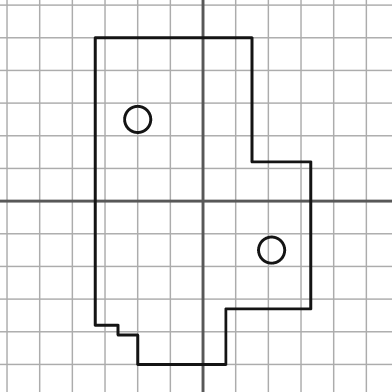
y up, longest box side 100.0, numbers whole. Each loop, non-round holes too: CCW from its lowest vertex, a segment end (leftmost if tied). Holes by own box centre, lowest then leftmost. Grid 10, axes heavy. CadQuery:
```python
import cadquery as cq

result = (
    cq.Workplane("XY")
    .moveTo(-20.0, -50.0)
    .lineTo(7.0, -50.0)
    .lineTo(7.0, -33.0)
    .lineTo(33.0, -33.0)
    .lineTo(33.0, 12.0)
    .lineTo(15.0, 12.0)
    .lineTo(15.0, 50.0)
    .lineTo(-33.0, 50.0)
    .lineTo(-33.0, -38.0)
    .lineTo(-26.0, -38.0)
    .lineTo(-26.0, -41.0)
    .lineTo(-20.0, -41.0)
    .close()
    .moveTo(21.0, -15.0)
    .circle(4.0)
    .moveTo(-20.0, 25.0)
    .circle(4.0)
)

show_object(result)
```